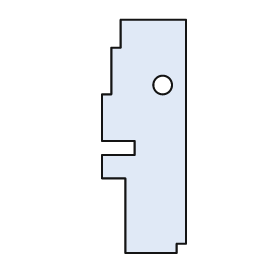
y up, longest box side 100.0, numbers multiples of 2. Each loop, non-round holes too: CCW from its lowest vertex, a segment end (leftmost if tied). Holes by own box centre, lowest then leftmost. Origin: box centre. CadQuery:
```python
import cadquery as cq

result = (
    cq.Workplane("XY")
    .moveTo(-8.0, -50.0)
    .lineTo(14.0, -50.0)
    .lineTo(14.0, -46.0)
    .lineTo(18.0, -46.0)
    .lineTo(18.0, 50.0)
    .lineTo(-10.0, 50.0)
    .lineTo(-10.0, 38.0)
    .lineTo(-14.0, 38.0)
    .lineTo(-14.0, 18.0)
    .lineTo(-18.0, 18.0)
    .lineTo(-18.0, -2.0)
    .lineTo(-4.0, -2.0)
    .lineTo(-4.0, -8.0)
    .lineTo(-18.0, -8.0)
    .lineTo(-18.0, -18.0)
    .lineTo(-8.0, -18.0)
    .close()
    .moveTo(8.0, 22.0)
    .circle(4.0)
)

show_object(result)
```